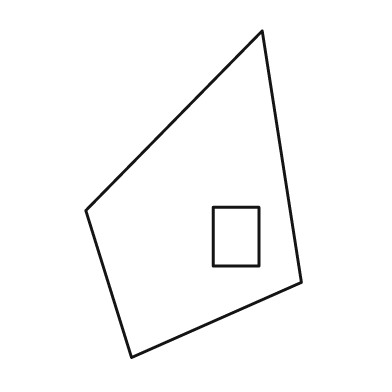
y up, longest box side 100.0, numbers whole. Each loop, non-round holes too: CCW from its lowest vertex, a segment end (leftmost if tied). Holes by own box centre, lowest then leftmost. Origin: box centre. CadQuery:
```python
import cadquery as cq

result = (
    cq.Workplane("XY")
    .moveTo(-19.0, -50.0)
    .lineTo(33.0, -27.0)
    .lineTo(21.0, 50.0)
    .lineTo(-33.0, -5.0)
    .close()
    .moveTo(6.0, -22.0)
    .lineTo(20.0, -22.0)
    .lineTo(20.0, -4.0)
    .lineTo(6.0, -4.0)
    .close()
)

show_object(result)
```